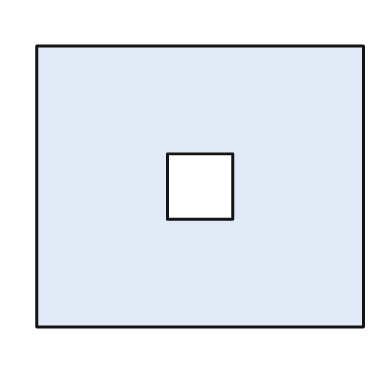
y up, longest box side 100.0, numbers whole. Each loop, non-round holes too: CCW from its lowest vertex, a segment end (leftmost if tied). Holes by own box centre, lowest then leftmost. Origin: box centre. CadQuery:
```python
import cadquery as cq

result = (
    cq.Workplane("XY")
    .moveTo(-50.0, -43.0)
    .lineTo(50.0, -43.0)
    .lineTo(50.0, 43.0)
    .lineTo(-50.0, 43.0)
    .close()
    .moveTo(-10.0, -10.0)
    .lineTo(10.0, -10.0)
    .lineTo(10.0, 10.0)
    .lineTo(-10.0, 10.0)
    .close()
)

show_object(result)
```